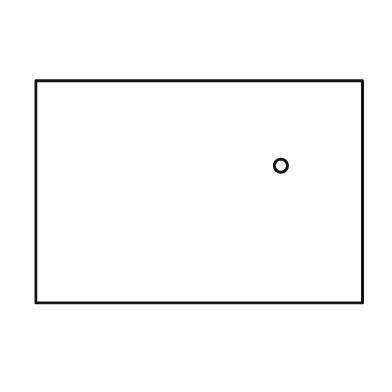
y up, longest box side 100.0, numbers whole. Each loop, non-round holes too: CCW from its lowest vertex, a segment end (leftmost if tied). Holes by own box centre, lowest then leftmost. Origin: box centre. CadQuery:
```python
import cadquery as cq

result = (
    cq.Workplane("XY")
    .moveTo(-50.0, -34.0)
    .lineTo(50.0, -34.0)
    .lineTo(50.0, 34.0)
    .lineTo(-50.0, 34.0)
    .close()
    .moveTo(25.0, 8.0)
    .circle(2.0)
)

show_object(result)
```